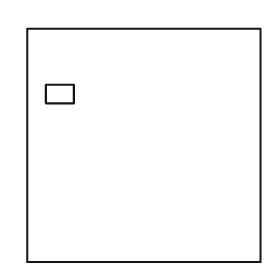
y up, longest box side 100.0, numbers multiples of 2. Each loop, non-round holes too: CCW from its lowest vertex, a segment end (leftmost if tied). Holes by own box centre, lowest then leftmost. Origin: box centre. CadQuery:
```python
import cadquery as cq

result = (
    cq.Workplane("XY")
    .moveTo(-50.0, -50.0)
    .lineTo(50.0, -50.0)
    .lineTo(50.0, 50.0)
    .lineTo(-50.0, 50.0)
    .close()
    .moveTo(-42.0, 18.0)
    .lineTo(-30.0, 18.0)
    .lineTo(-30.0, 26.0)
    .lineTo(-42.0, 26.0)
    .close()
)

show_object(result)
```